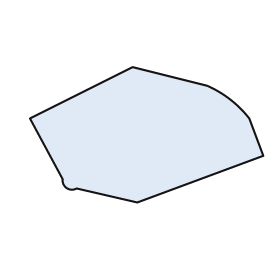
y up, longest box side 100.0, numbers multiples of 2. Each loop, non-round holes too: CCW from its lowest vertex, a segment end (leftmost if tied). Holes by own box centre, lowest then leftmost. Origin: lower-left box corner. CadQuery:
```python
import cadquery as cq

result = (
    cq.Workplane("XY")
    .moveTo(46.0, 0.0)
    .lineTo(100.0, 20.0)
    .lineTo(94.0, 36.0)
    .threePointArc((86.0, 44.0), (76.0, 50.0))
    .lineTo(44.0, 58.0)
    .lineTo(0.0, 36.0)
    .lineTo(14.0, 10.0)
    .threePointArc((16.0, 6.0), (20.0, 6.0))
    .close()
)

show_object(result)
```